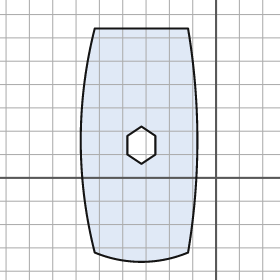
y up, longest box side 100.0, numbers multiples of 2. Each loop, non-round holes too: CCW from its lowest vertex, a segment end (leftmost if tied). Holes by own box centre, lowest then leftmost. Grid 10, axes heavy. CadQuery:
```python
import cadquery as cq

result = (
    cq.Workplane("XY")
    .moveTo(-52.0, -32.0)
    .threePointArc((-32.0, -36.0), (-12.0, -32.0))
    .threePointArc((-8.0, 16.0), (-12.0, 64.0))
    .lineTo(-52.0, 64.0)
    .threePointArc((-58.0, 16.0), (-52.0, -32.0))
    .close()
    .moveTo(-32.0, 6.0)
    .lineTo(-26.0, 10.0)
    .lineTo(-26.0, 18.0)
    .lineTo(-32.0, 22.0)
    .lineTo(-38.0, 18.0)
    .lineTo(-38.0, 10.0)
    .close()
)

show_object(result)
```